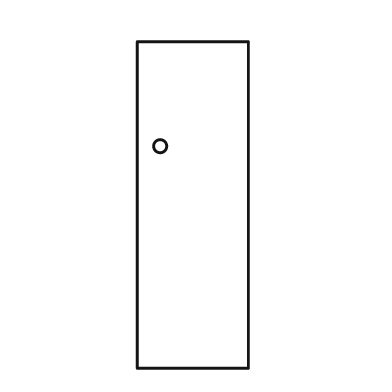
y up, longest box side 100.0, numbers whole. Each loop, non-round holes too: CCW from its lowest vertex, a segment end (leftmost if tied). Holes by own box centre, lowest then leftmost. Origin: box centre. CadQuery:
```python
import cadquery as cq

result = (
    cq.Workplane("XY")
    .moveTo(-17.0, -50.0)
    .lineTo(17.0, -50.0)
    .lineTo(17.0, 50.0)
    .lineTo(-17.0, 50.0)
    .close()
    .moveTo(-10.0, 18.0)
    .circle(2.0)
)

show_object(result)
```